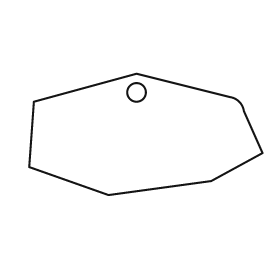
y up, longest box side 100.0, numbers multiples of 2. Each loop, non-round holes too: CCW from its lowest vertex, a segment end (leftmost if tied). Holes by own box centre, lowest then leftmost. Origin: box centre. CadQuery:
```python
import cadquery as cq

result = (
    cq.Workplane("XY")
    .moveTo(-16.0, -26.0)
    .lineTo(28.0, -20.0)
    .lineTo(50.0, -8.0)
    .lineTo(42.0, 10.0)
    .threePointArc((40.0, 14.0), (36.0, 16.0))
    .lineTo(-4.0, 26.0)
    .lineTo(-48.0, 14.0)
    .lineTo(-50.0, -14.0)
    .close()
    .moveTo(-4.0, 18.0)
    .circle(4.0)
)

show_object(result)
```